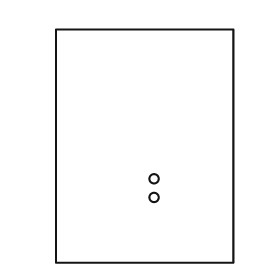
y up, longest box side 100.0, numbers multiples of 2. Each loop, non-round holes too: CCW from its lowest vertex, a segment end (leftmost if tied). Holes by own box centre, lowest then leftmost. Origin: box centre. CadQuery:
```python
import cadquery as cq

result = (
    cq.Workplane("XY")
    .moveTo(-38.0, -50.0)
    .lineTo(38.0, -50.0)
    .lineTo(38.0, 50.0)
    .lineTo(-38.0, 50.0)
    .close()
    .moveTo(4.0, -22.0)
    .circle(2.0)
    .moveTo(4.0, -14.0)
    .circle(2.0)
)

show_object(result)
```